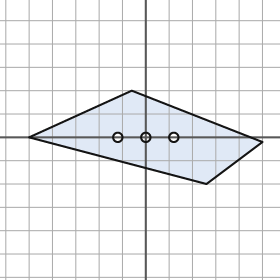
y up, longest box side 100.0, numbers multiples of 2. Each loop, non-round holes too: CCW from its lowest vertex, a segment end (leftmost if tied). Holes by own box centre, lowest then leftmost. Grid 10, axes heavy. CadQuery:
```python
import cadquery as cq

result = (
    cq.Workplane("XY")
    .moveTo(26.0, -20.0)
    .lineTo(50.0, -2.0)
    .lineTo(-6.0, 20.0)
    .lineTo(-50.0, 0.0)
    .close()
    .moveTo(-12.0, 0.0)
    .circle(2.0)
    .moveTo(0.0, 0.0)
    .circle(2.0)
    .moveTo(12.0, 0.0)
    .circle(2.0)
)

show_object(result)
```